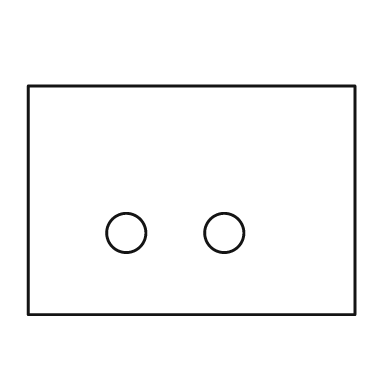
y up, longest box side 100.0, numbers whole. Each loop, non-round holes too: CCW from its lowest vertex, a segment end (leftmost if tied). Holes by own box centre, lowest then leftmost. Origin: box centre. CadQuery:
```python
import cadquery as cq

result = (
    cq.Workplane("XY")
    .moveTo(-50.0, -35.0)
    .lineTo(50.0, -35.0)
    .lineTo(50.0, 35.0)
    .lineTo(-50.0, 35.0)
    .close()
    .moveTo(-20.0, -10.0)
    .circle(6.0)
    .moveTo(10.0, -10.0)
    .circle(6.0)
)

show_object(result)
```